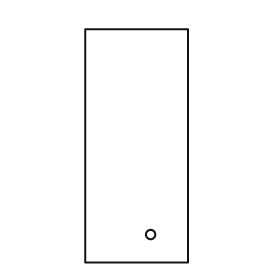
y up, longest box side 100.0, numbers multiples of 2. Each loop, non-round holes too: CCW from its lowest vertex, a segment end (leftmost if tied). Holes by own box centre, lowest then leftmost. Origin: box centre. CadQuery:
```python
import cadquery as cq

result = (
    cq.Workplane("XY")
    .moveTo(-22.0, -50.0)
    .lineTo(22.0, -50.0)
    .lineTo(22.0, 50.0)
    .lineTo(-22.0, 50.0)
    .close()
    .moveTo(6.0, -38.0)
    .circle(2.0)
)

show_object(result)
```